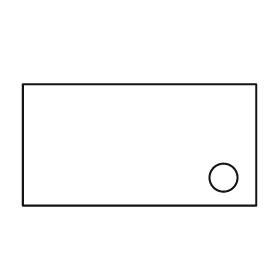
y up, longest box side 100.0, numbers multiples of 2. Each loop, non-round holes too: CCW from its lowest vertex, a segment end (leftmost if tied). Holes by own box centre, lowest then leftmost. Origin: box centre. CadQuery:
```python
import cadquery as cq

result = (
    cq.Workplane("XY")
    .moveTo(-50.0, -26.0)
    .lineTo(50.0, -26.0)
    .lineTo(50.0, 26.0)
    .lineTo(-50.0, 26.0)
    .close()
    .moveTo(36.0, -14.0)
    .circle(6.0)
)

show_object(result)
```